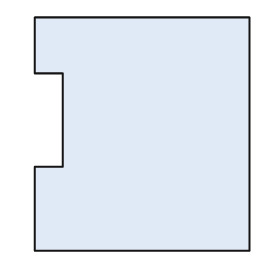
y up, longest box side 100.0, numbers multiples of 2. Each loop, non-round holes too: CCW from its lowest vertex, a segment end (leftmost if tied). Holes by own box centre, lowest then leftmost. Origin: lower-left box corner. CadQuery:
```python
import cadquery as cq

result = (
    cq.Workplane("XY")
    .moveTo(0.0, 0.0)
    .lineTo(92.0, 0.0)
    .lineTo(92.0, 100.0)
    .lineTo(0.0, 100.0)
    .lineTo(0.0, 76.0)
    .lineTo(12.0, 76.0)
    .lineTo(12.0, 36.0)
    .lineTo(0.0, 36.0)
    .close()
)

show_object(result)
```